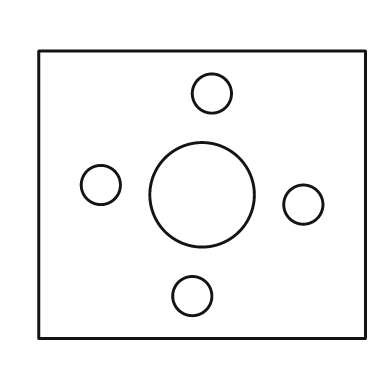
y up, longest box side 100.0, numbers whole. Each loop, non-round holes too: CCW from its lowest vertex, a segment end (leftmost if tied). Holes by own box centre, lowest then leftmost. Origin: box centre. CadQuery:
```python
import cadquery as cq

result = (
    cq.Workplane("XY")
    .moveTo(-50.0, -44.0)
    .lineTo(50.0, -44.0)
    .lineTo(50.0, 44.0)
    .lineTo(-50.0, 44.0)
    .close()
    .moveTo(-3.0, -31.0)
    .circle(6.0)
    .moveTo(31.0, -3.0)
    .circle(6.0)
    .moveTo(0.0, 0.0)
    .circle(16.0)
    .moveTo(-31.0, 3.0)
    .circle(6.0)
    .moveTo(3.0, 31.0)
    .circle(6.0)
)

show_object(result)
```